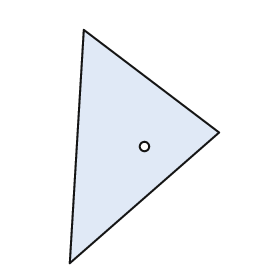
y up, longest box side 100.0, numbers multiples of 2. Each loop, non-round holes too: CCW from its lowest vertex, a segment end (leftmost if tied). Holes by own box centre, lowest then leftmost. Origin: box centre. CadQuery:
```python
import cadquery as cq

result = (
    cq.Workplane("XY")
    .moveTo(-32.0, -50.0)
    .lineTo(32.0, 6.0)
    .lineTo(-26.0, 50.0)
    .close()
    .moveTo(0.0, 0.0)
    .circle(2.0)
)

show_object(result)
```